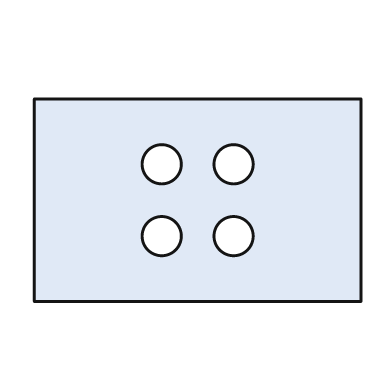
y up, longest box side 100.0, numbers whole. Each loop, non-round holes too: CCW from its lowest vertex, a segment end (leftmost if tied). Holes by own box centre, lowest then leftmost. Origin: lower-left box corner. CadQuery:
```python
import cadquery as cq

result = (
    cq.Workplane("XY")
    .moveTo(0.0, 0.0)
    .lineTo(100.0, 0.0)
    .lineTo(100.0, 62.0)
    .lineTo(0.0, 62.0)
    .close()
    .moveTo(39.0, 20.0)
    .circle(6.0)
    .moveTo(61.0, 20.0)
    .circle(6.0)
    .moveTo(39.0, 42.0)
    .circle(6.0)
    .moveTo(61.0, 42.0)
    .circle(6.0)
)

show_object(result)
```